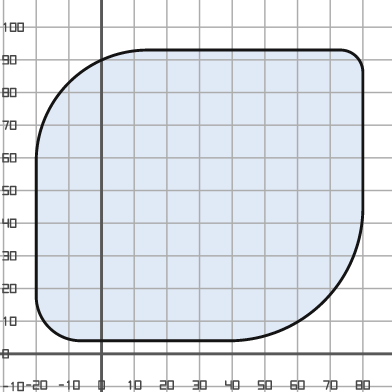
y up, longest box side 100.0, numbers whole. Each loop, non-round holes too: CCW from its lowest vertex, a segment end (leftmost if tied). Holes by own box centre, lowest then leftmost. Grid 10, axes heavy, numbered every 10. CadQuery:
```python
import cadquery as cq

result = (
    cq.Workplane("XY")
    .moveTo(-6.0, 4.0)
    .lineTo(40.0, 4.0)
    .threePointArc((68.0, 16.0), (80.0, 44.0))
    .lineTo(80.0, 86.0)
    .threePointArc((78.0, 91.0), (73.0, 93.0))
    .lineTo(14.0, 93.0)
    .threePointArc((-10.0, 83.0), (-20.0, 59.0))
    .lineTo(-20.0, 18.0)
    .threePointArc((-16.0, 8.0), (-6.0, 4.0))
    .close()
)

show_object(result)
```